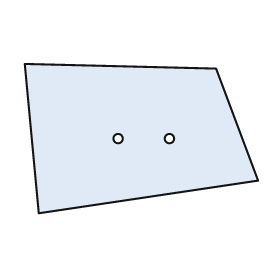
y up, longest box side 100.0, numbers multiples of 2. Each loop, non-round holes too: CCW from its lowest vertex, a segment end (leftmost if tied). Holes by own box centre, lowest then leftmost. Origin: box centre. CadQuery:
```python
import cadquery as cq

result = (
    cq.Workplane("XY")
    .moveTo(-44.0, -32.0)
    .lineTo(50.0, -18.0)
    .lineTo(32.0, 30.0)
    .lineTo(-50.0, 32.0)
    .close()
    .moveTo(-10.0, 0.0)
    .circle(2.0)
    .moveTo(12.0, 0.0)
    .circle(2.0)
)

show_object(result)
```